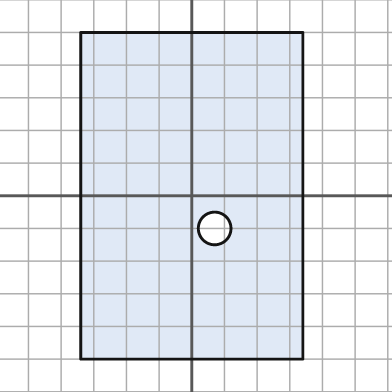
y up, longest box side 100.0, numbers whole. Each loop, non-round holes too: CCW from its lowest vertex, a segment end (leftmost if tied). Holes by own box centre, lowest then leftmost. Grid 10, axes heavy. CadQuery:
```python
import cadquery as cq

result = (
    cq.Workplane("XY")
    .moveTo(-34.0, -50.0)
    .lineTo(34.0, -50.0)
    .lineTo(34.0, 50.0)
    .lineTo(-34.0, 50.0)
    .close()
    .moveTo(7.0, -10.0)
    .circle(5.0)
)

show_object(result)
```